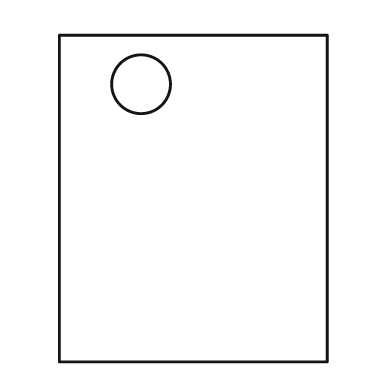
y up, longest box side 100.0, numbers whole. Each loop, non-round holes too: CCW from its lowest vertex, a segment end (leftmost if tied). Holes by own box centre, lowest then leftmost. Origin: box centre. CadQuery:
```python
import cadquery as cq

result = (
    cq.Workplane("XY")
    .moveTo(-41.0, -50.0)
    .lineTo(41.0, -50.0)
    .lineTo(41.0, 50.0)
    .lineTo(-41.0, 50.0)
    .close()
    .moveTo(-16.0, 35.0)
    .circle(9.0)
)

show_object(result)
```